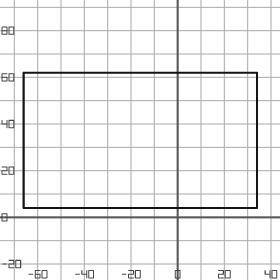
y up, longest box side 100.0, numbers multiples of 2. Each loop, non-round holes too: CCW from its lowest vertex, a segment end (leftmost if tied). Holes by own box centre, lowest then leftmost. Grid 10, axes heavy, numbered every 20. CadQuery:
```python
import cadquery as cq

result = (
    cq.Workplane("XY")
    .moveTo(-66.0, 4.0)
    .lineTo(34.0, 4.0)
    .lineTo(34.0, 62.0)
    .lineTo(-66.0, 62.0)
    .close()
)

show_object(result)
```